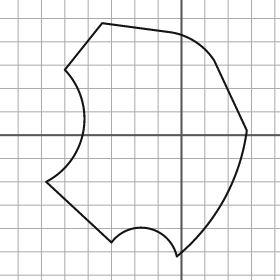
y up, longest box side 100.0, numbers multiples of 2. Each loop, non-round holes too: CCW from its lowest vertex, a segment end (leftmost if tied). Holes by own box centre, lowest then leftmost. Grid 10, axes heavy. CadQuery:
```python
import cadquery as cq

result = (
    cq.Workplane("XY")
    .moveTo(-2.0, -52.0)
    .threePointArc((18.0, -28.0), (28.0, 2.0))
    .lineTo(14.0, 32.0)
    .threePointArc((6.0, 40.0), (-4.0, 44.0))
    .lineTo(-34.0, 48.0)
    .lineTo(-50.0, 28.0)
    .threePointArc((-42.0, 2.0), (-58.0, -20.0))
    .lineTo(-30.0, -46.0)
    .threePointArc((-14.0, -40.0), (-2.0, -52.0))
    .close()
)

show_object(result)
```